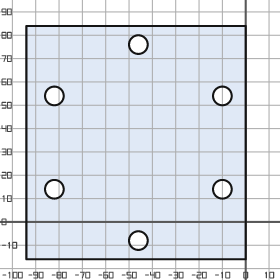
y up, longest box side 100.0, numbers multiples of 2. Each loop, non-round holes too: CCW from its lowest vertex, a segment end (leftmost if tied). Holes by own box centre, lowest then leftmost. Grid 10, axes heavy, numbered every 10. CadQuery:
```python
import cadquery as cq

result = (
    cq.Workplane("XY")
    .moveTo(-94.0, -16.0)
    .lineTo(0.0, -16.0)
    .lineTo(0.0, 84.0)
    .lineTo(-94.0, 84.0)
    .close()
    .moveTo(-46.0, -8.0)
    .circle(4.0)
    .moveTo(-82.0, 14.0)
    .circle(4.0)
    .moveTo(-10.0, 14.0)
    .circle(4.0)
    .moveTo(-82.0, 54.0)
    .circle(4.0)
    .moveTo(-10.0, 54.0)
    .circle(4.0)
    .moveTo(-46.0, 76.0)
    .circle(4.0)
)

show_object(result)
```